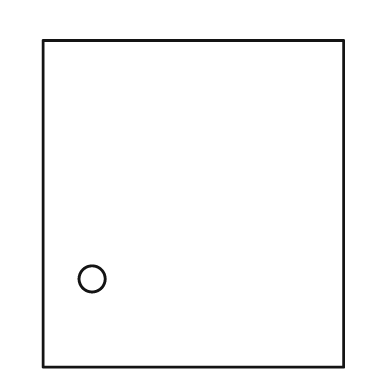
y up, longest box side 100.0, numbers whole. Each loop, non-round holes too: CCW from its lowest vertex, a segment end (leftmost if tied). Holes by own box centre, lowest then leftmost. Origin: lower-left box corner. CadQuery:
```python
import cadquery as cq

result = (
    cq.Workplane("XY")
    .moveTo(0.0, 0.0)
    .lineTo(92.0, 0.0)
    .lineTo(92.0, 100.0)
    .lineTo(0.0, 100.0)
    .close()
    .moveTo(15.0, 27.0)
    .circle(4.0)
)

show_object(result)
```